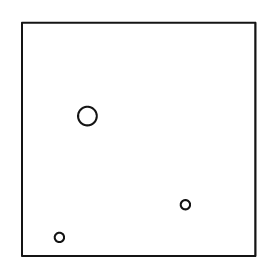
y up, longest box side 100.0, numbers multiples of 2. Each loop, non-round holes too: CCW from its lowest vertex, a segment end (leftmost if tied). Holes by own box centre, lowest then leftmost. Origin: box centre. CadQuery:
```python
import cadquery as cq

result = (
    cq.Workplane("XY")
    .moveTo(-50.0, -50.0)
    .lineTo(50.0, -50.0)
    .lineTo(50.0, 50.0)
    .lineTo(-50.0, 50.0)
    .close()
    .moveTo(-34.0, -42.0)
    .circle(2.0)
    .moveTo(20.0, -28.0)
    .circle(2.0)
    .moveTo(-22.0, 10.0)
    .circle(4.0)
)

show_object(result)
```